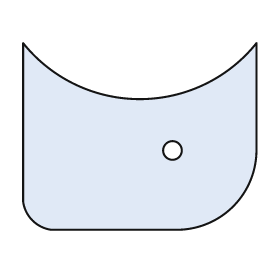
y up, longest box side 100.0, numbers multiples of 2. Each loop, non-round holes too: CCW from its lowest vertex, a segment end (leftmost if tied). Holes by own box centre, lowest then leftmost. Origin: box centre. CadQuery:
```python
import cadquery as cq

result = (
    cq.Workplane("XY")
    .moveTo(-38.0, -40.0)
    .lineTo(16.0, -40.0)
    .threePointArc((40.0, -30.0), (50.0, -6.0))
    .lineTo(50.0, 40.0)
    .threePointArc((0.0, 16.0), (-50.0, 40.0))
    .lineTo(-50.0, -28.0)
    .threePointArc((-46.0, -36.0), (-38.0, -40.0))
    .close()
    .moveTo(14.0, -6.0)
    .circle(4.0)
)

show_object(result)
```